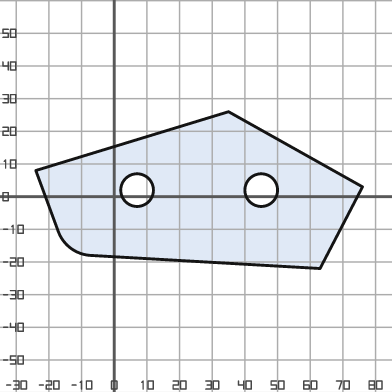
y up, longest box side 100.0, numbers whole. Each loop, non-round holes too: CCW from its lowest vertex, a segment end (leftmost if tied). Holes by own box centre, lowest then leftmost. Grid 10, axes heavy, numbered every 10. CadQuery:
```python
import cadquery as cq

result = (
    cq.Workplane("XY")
    .moveTo(63.0, -22.0)
    .lineTo(76.0, 3.0)
    .lineTo(35.0, 26.0)
    .lineTo(-24.0, 8.0)
    .lineTo(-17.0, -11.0)
    .threePointArc((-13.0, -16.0), (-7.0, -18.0))
    .close()
    .moveTo(7.0, 2.0)
    .circle(5.0)
    .moveTo(45.0, 2.0)
    .circle(5.0)
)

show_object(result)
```